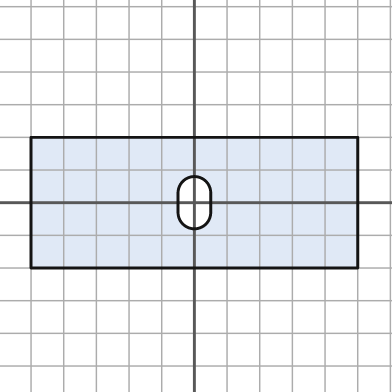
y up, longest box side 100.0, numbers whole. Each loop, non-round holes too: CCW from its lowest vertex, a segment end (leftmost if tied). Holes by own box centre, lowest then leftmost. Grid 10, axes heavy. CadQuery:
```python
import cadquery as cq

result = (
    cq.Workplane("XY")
    .moveTo(-50.0, -20.0)
    .lineTo(50.0, -20.0)
    .lineTo(50.0, 20.0)
    .lineTo(-50.0, 20.0)
    .close()
    .moveTo(-5.0, -3.0)
    .threePointArc((0.0, -8.0), (5.0, -3.0))
    .lineTo(5.0, 3.0)
    .threePointArc((0.0, 8.0), (-5.0, 3.0))
    .close()
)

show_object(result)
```